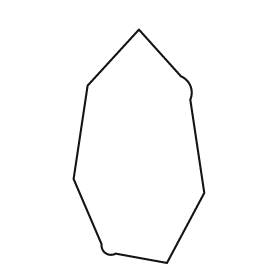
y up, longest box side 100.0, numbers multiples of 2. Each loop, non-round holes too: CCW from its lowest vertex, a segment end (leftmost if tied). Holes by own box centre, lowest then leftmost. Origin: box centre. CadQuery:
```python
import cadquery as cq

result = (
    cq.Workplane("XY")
    .moveTo(12.0, -50.0)
    .lineTo(28.0, -20.0)
    .lineTo(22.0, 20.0)
    .threePointArc((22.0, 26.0), (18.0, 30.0))
    .lineTo(0.0, 50.0)
    .lineTo(-22.0, 26.0)
    .lineTo(-28.0, -14.0)
    .lineTo(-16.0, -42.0)
    .threePointArc((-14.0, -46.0), (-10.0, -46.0))
    .close()
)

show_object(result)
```